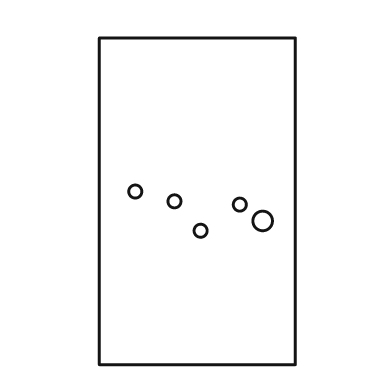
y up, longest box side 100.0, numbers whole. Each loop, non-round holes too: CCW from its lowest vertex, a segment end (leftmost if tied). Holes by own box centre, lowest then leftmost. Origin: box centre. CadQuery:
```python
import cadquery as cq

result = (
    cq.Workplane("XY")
    .moveTo(-30.0, -50.0)
    .lineTo(30.0, -50.0)
    .lineTo(30.0, 50.0)
    .lineTo(-30.0, 50.0)
    .close()
    .moveTo(1.0, -9.0)
    .circle(2.0)
    .moveTo(20.0, -6.0)
    .circle(3.0)
    .moveTo(13.0, -1.0)
    .circle(2.0)
    .moveTo(-7.0, 0.0)
    .circle(2.0)
    .moveTo(-19.0, 3.0)
    .circle(2.0)
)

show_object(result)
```